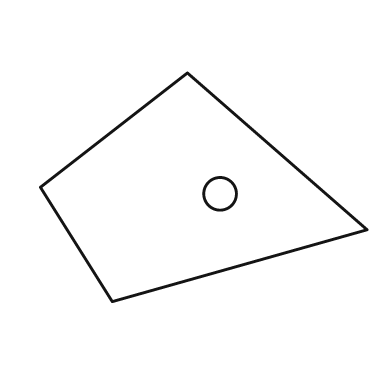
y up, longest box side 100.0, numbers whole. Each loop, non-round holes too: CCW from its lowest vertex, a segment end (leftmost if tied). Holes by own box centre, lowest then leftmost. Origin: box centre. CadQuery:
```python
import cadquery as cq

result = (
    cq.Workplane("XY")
    .moveTo(-28.0, -35.0)
    .lineTo(50.0, -13.0)
    .lineTo(-5.0, 35.0)
    .lineTo(-50.0, 0.0)
    .close()
    .moveTo(5.0, -2.0)
    .circle(5.0)
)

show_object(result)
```